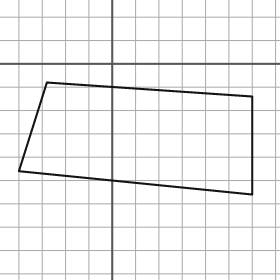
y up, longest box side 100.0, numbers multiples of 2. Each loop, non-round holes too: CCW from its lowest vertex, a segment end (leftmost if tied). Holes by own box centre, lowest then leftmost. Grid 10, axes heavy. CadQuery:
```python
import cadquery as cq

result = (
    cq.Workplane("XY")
    .moveTo(60.0, -56.0)
    .lineTo(60.0, -14.0)
    .lineTo(-28.0, -8.0)
    .lineTo(-40.0, -46.0)
    .close()
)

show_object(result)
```